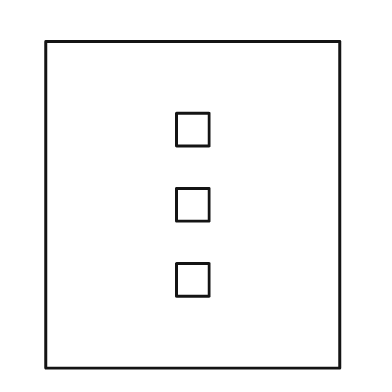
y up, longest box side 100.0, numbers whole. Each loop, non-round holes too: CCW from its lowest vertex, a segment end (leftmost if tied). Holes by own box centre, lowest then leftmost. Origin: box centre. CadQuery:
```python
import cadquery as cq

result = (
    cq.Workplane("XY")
    .moveTo(-45.0, -50.0)
    .lineTo(45.0, -50.0)
    .lineTo(45.0, 50.0)
    .lineTo(-45.0, 50.0)
    .close()
    .moveTo(-5.0, -28.0)
    .lineTo(5.0, -28.0)
    .lineTo(5.0, -18.0)
    .lineTo(-5.0, -18.0)
    .close()
    .moveTo(-5.0, -5.0)
    .lineTo(5.0, -5.0)
    .lineTo(5.0, 5.0)
    .lineTo(-5.0, 5.0)
    .close()
    .moveTo(-5.0, 18.0)
    .lineTo(5.0, 18.0)
    .lineTo(5.0, 28.0)
    .lineTo(-5.0, 28.0)
    .close()
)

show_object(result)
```